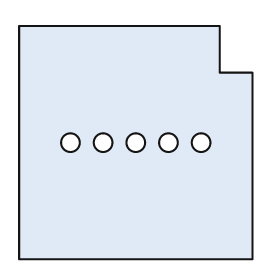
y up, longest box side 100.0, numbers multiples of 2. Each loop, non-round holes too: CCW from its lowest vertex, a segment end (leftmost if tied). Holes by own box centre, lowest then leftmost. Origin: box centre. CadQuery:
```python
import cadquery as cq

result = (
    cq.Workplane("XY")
    .moveTo(-50.0, -50.0)
    .lineTo(50.0, -50.0)
    .lineTo(50.0, 30.0)
    .lineTo(36.0, 30.0)
    .lineTo(36.0, 50.0)
    .lineTo(-50.0, 50.0)
    .close()
    .moveTo(-28.0, 0.0)
    .circle(4.0)
    .moveTo(-14.0, 0.0)
    .circle(4.0)
    .moveTo(0.0, 0.0)
    .circle(4.0)
    .moveTo(14.0, 0.0)
    .circle(4.0)
    .moveTo(28.0, 0.0)
    .circle(4.0)
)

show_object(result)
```